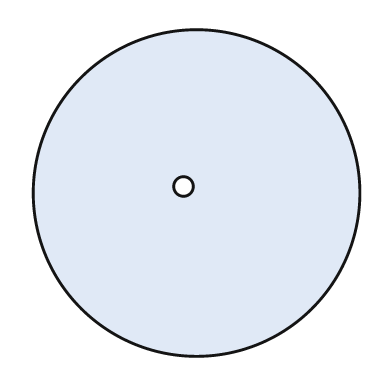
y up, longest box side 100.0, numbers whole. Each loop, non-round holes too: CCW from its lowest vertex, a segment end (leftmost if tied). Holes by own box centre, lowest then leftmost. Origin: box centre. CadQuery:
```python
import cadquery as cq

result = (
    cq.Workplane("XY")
    .moveTo(0.0, 0.0)
    .circle(50.0)
    .moveTo(-4.0, 2.0)
    .circle(3.0)
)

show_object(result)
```